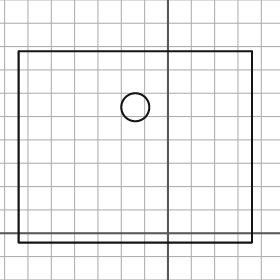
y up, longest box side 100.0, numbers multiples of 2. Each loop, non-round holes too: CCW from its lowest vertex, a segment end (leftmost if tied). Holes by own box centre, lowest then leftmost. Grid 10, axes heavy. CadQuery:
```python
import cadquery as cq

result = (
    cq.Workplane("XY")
    .moveTo(-64.0, -4.0)
    .lineTo(36.0, -4.0)
    .lineTo(36.0, 78.0)
    .lineTo(-64.0, 78.0)
    .close()
    .moveTo(-14.0, 54.0)
    .circle(6.0)
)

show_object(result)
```